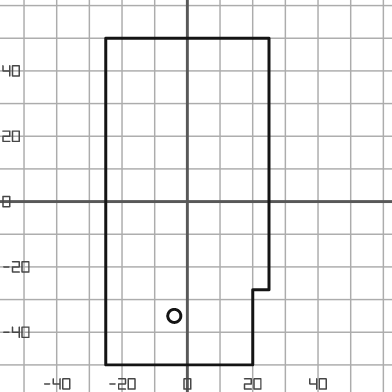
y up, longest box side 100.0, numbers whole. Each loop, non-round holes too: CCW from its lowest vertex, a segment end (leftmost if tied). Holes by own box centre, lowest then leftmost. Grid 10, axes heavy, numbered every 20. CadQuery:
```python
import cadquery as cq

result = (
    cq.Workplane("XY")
    .moveTo(-25.0, -50.0)
    .lineTo(20.0, -50.0)
    .lineTo(20.0, -27.0)
    .lineTo(25.0, -27.0)
    .lineTo(25.0, 50.0)
    .lineTo(-25.0, 50.0)
    .close()
    .moveTo(-4.0, -35.0)
    .circle(2.0)
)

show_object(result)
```